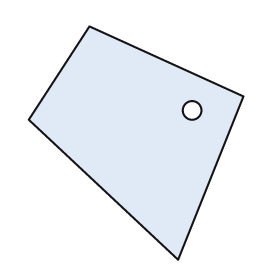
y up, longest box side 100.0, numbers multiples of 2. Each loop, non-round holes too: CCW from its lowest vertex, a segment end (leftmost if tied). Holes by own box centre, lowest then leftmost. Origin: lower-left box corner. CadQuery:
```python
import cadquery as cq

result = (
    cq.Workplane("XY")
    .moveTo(64.0, 0.0)
    .lineTo(92.0, 70.0)
    .lineTo(26.0, 100.0)
    .lineTo(0.0, 60.0)
    .close()
    .moveTo(70.0, 64.0)
    .circle(4.0)
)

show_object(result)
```